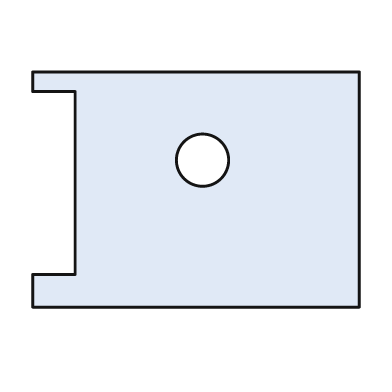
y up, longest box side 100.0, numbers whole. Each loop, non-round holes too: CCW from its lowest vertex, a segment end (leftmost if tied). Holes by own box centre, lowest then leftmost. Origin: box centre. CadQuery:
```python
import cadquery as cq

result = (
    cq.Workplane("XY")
    .moveTo(-50.0, -36.0)
    .lineTo(50.0, -36.0)
    .lineTo(50.0, 36.0)
    .lineTo(-50.0, 36.0)
    .lineTo(-50.0, 30.0)
    .lineTo(-37.0, 30.0)
    .lineTo(-37.0, -26.0)
    .lineTo(-50.0, -26.0)
    .close()
    .moveTo(2.0, 9.0)
    .circle(8.0)
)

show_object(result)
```